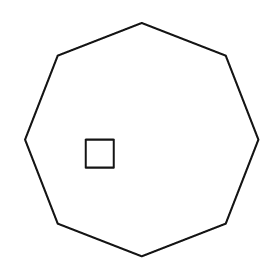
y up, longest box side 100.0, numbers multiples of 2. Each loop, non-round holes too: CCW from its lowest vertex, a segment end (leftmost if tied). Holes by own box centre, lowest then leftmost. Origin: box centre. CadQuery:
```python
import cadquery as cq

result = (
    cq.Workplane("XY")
    .moveTo(0.0, -50.0)
    .lineTo(36.0, -36.0)
    .lineTo(50.0, 0.0)
    .lineTo(36.0, 36.0)
    .lineTo(0.0, 50.0)
    .lineTo(-36.0, 36.0)
    .lineTo(-50.0, 0.0)
    .lineTo(-36.0, -36.0)
    .close()
    .moveTo(-24.0, -12.0)
    .lineTo(-12.0, -12.0)
    .lineTo(-12.0, 0.0)
    .lineTo(-24.0, 0.0)
    .close()
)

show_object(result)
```